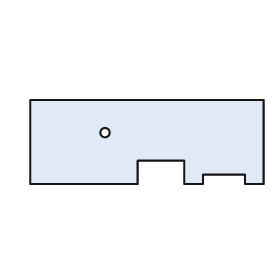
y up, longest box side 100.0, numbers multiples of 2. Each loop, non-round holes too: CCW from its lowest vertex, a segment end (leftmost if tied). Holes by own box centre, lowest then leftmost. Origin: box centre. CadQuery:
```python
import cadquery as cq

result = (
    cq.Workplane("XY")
    .moveTo(-50.0, -18.0)
    .lineTo(-4.0, -18.0)
    .lineTo(-4.0, -8.0)
    .lineTo(16.0, -8.0)
    .lineTo(16.0, -18.0)
    .lineTo(24.0, -18.0)
    .lineTo(24.0, -14.0)
    .lineTo(42.0, -14.0)
    .lineTo(42.0, -18.0)
    .lineTo(50.0, -18.0)
    .lineTo(50.0, 18.0)
    .lineTo(-50.0, 18.0)
    .close()
    .moveTo(-18.0, 4.0)
    .circle(2.0)
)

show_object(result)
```